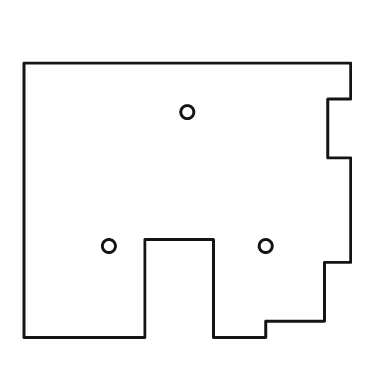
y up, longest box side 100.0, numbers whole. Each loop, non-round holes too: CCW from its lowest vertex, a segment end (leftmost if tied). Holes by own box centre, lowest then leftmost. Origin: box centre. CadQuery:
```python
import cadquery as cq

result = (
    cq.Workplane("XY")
    .moveTo(-50.0, -42.0)
    .lineTo(-13.0, -42.0)
    .lineTo(-13.0, -12.0)
    .lineTo(8.0, -12.0)
    .lineTo(8.0, -42.0)
    .lineTo(24.0, -42.0)
    .lineTo(24.0, -37.0)
    .lineTo(42.0, -37.0)
    .lineTo(42.0, -19.0)
    .lineTo(50.0, -19.0)
    .lineTo(50.0, 13.0)
    .lineTo(43.0, 13.0)
    .lineTo(43.0, 31.0)
    .lineTo(50.0, 31.0)
    .lineTo(50.0, 42.0)
    .lineTo(-50.0, 42.0)
    .close()
    .moveTo(-24.0, -14.0)
    .circle(2.0)
    .moveTo(24.0, -14.0)
    .circle(2.0)
    .moveTo(0.0, 27.0)
    .circle(2.0)
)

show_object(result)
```